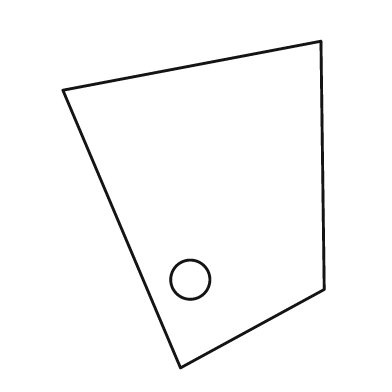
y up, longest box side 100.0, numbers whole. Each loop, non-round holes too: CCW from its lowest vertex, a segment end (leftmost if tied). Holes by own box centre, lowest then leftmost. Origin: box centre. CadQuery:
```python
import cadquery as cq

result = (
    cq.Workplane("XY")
    .moveTo(-4.0, -50.0)
    .lineTo(40.0, -26.0)
    .lineTo(39.0, 50.0)
    .lineTo(-40.0, 35.0)
    .close()
    .moveTo(-1.0, -23.0)
    .circle(6.0)
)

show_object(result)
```